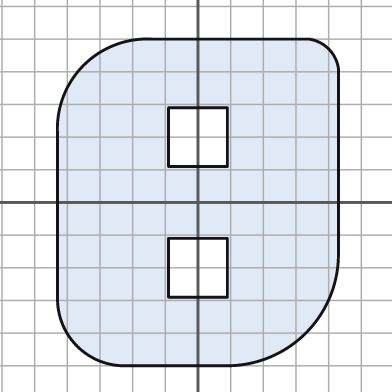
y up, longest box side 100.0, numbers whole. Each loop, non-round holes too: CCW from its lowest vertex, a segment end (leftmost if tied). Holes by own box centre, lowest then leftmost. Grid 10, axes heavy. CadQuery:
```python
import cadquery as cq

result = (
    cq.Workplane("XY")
    .moveTo(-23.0, -50.0)
    .lineTo(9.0, -50.0)
    .threePointArc((33.0, -40.0), (43.0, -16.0))
    .lineTo(43.0, 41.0)
    .threePointArc((40.0, 47.0), (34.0, 50.0))
    .lineTo(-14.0, 50.0)
    .threePointArc((-35.0, 42.0), (-43.0, 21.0))
    .lineTo(-43.0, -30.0)
    .threePointArc((-37.0, -44.0), (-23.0, -50.0))
    .close()
    .moveTo(-9.0, -29.0)
    .lineTo(9.0, -29.0)
    .lineTo(9.0, -11.0)
    .lineTo(-9.0, -11.0)
    .close()
    .moveTo(-9.0, 11.0)
    .lineTo(9.0, 11.0)
    .lineTo(9.0, 29.0)
    .lineTo(-9.0, 29.0)
    .close()
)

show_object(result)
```